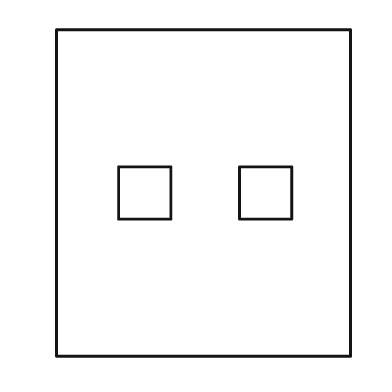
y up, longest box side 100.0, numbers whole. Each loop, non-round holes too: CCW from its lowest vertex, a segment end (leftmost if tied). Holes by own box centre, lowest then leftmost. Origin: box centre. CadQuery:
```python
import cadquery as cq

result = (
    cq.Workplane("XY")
    .moveTo(-45.0, -50.0)
    .lineTo(45.0, -50.0)
    .lineTo(45.0, 50.0)
    .lineTo(-45.0, 50.0)
    .close()
    .moveTo(-26.0, -8.0)
    .lineTo(-10.0, -8.0)
    .lineTo(-10.0, 8.0)
    .lineTo(-26.0, 8.0)
    .close()
    .moveTo(11.0, -8.0)
    .lineTo(27.0, -8.0)
    .lineTo(27.0, 8.0)
    .lineTo(11.0, 8.0)
    .close()
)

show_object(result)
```